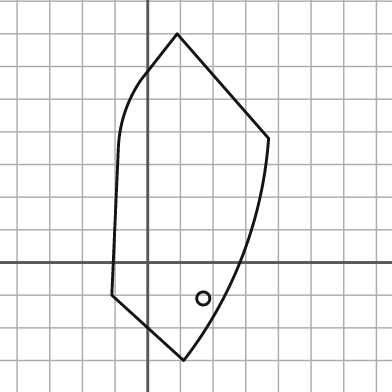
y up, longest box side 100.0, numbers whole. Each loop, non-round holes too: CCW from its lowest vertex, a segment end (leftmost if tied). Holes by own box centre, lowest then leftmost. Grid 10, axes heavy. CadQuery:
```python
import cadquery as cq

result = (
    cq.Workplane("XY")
    .moveTo(11.0, -30.0)
    .threePointArc((29.0, 2.0), (37.0, 38.0))
    .lineTo(9.0, 70.0)
    .lineTo(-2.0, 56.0)
    .threePointArc((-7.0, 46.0), (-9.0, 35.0))
    .lineTo(-11.0, -10.0)
    .close()
    .moveTo(17.0, -11.0)
    .circle(2.0)
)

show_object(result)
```